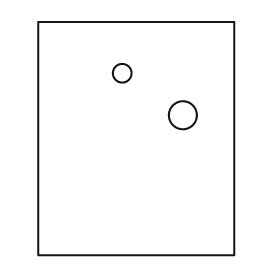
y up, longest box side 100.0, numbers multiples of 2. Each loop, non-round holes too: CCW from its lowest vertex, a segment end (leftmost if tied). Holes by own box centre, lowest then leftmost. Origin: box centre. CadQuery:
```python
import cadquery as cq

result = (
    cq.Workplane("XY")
    .moveTo(-42.0, -50.0)
    .lineTo(42.0, -50.0)
    .lineTo(42.0, 50.0)
    .lineTo(-42.0, 50.0)
    .close()
    .moveTo(20.0, 10.0)
    .circle(6.0)
    .moveTo(-6.0, 28.0)
    .circle(4.0)
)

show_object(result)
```